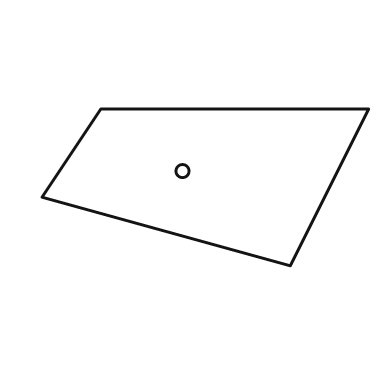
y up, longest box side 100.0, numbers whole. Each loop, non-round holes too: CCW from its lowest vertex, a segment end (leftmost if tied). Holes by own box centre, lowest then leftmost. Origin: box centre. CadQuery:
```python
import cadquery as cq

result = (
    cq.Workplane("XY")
    .moveTo(26.0, -24.0)
    .lineTo(50.0, 24.0)
    .lineTo(-32.0, 24.0)
    .lineTo(-50.0, -3.0)
    .close()
    .moveTo(-7.0, 5.0)
    .circle(2.0)
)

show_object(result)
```